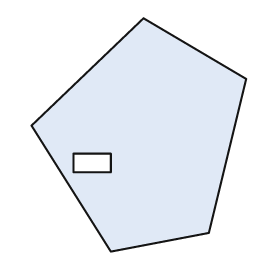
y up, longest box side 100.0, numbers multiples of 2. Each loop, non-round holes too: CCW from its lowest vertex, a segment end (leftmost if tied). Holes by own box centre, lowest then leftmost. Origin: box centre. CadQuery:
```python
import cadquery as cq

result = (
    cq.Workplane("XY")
    .moveTo(-12.0, -50.0)
    .lineTo(30.0, -42.0)
    .lineTo(46.0, 24.0)
    .lineTo(2.0, 50.0)
    .lineTo(-46.0, 4.0)
    .close()
    .moveTo(-28.0, -16.0)
    .lineTo(-12.0, -16.0)
    .lineTo(-12.0, -8.0)
    .lineTo(-28.0, -8.0)
    .close()
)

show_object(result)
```